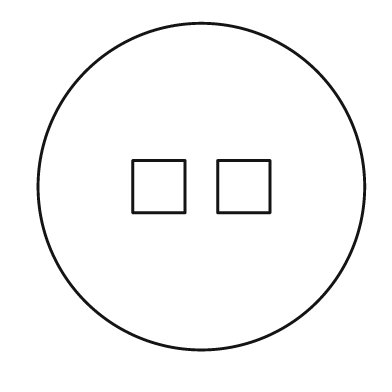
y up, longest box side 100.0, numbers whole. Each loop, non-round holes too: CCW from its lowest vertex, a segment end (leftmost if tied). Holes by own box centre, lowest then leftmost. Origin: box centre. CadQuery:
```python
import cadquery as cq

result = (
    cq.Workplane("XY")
    .moveTo(0.0, 0.0)
    .circle(50.0)
    .moveTo(-21.0, -8.0)
    .lineTo(-5.0, -8.0)
    .lineTo(-5.0, 8.0)
    .lineTo(-21.0, 8.0)
    .close()
    .moveTo(5.0, -8.0)
    .lineTo(21.0, -8.0)
    .lineTo(21.0, 8.0)
    .lineTo(5.0, 8.0)
    .close()
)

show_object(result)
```